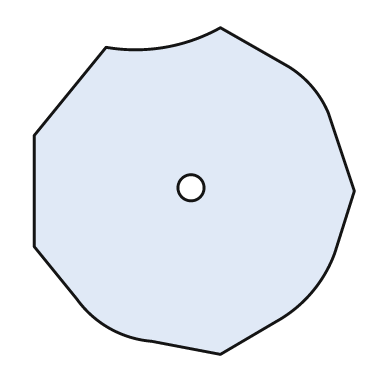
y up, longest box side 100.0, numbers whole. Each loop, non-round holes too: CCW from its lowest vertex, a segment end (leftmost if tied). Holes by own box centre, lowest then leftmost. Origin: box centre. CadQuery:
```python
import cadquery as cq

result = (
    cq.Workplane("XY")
    .moveTo(8.0, -50.0)
    .lineTo(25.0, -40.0)
    .threePointArc((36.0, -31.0), (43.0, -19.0))
    .lineTo(49.0, 0.0)
    .lineTo(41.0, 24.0)
    .threePointArc((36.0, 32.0), (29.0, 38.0))
    .lineTo(8.0, 50.0)
    .threePointArc((-9.0, 44.0), (-27.0, 44.0))
    .lineTo(-49.0, 17.0)
    .lineTo(-49.0, -17.0)
    .lineTo(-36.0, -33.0)
    .threePointArc((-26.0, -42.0), (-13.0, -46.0))
    .close()
    .moveTo(-1.0, 1.0)
    .circle(4.0)
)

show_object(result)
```